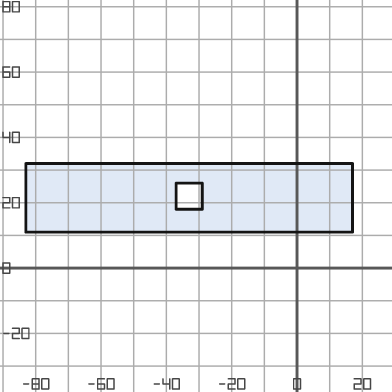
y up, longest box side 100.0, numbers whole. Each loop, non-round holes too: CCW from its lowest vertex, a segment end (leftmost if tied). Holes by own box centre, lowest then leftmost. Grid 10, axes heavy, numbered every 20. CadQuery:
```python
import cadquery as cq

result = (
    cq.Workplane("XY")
    .moveTo(-83.0, 11.0)
    .lineTo(17.0, 11.0)
    .lineTo(17.0, 32.0)
    .lineTo(-83.0, 32.0)
    .close()
    .moveTo(-37.0, 18.0)
    .lineTo(-29.0, 18.0)
    .lineTo(-29.0, 26.0)
    .lineTo(-37.0, 26.0)
    .close()
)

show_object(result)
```